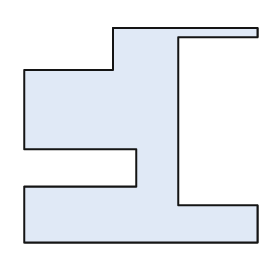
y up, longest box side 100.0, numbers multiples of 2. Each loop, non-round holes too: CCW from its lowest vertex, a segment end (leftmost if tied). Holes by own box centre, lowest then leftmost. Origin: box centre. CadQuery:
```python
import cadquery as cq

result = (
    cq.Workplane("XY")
    .moveTo(-50.0, -46.0)
    .lineTo(50.0, -46.0)
    .lineTo(50.0, -30.0)
    .lineTo(16.0, -30.0)
    .lineTo(16.0, 42.0)
    .lineTo(50.0, 42.0)
    .lineTo(50.0, 46.0)
    .lineTo(-12.0, 46.0)
    .lineTo(-12.0, 28.0)
    .lineTo(-50.0, 28.0)
    .lineTo(-50.0, -6.0)
    .lineTo(-2.0, -6.0)
    .lineTo(-2.0, -22.0)
    .lineTo(-50.0, -22.0)
    .close()
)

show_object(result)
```